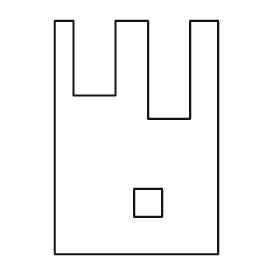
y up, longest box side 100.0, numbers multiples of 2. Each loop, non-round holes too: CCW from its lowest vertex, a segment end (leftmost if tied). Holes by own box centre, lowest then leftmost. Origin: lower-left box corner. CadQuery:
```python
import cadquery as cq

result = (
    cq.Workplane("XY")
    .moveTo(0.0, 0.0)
    .lineTo(70.0, 0.0)
    .lineTo(70.0, 100.0)
    .lineTo(58.0, 100.0)
    .lineTo(58.0, 58.0)
    .lineTo(40.0, 58.0)
    .lineTo(40.0, 100.0)
    .lineTo(26.0, 100.0)
    .lineTo(26.0, 68.0)
    .lineTo(8.0, 68.0)
    .lineTo(8.0, 100.0)
    .lineTo(0.0, 100.0)
    .close()
    .moveTo(34.0, 16.0)
    .lineTo(46.0, 16.0)
    .lineTo(46.0, 28.0)
    .lineTo(34.0, 28.0)
    .close()
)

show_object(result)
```